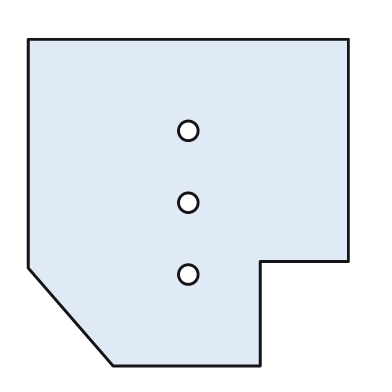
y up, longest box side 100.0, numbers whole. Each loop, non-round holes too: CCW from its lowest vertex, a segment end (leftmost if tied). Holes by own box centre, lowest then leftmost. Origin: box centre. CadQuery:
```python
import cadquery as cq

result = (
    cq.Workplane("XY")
    .moveTo(-23.0, -50.0)
    .lineTo(22.0, -50.0)
    .lineTo(22.0, -18.0)
    .lineTo(49.0, -18.0)
    .lineTo(49.0, 50.0)
    .lineTo(-49.0, 50.0)
    .lineTo(-49.0, -20.0)
    .close()
    .moveTo(0.0, -22.0)
    .circle(3.0)
    .moveTo(0.0, 0.0)
    .circle(3.0)
    .moveTo(0.0, 22.0)
    .circle(3.0)
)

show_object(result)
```